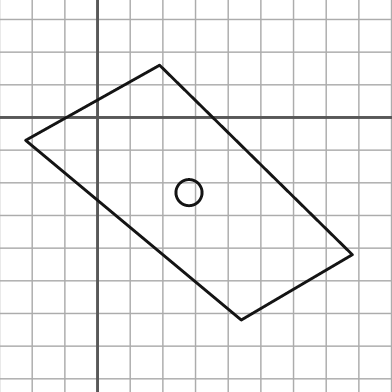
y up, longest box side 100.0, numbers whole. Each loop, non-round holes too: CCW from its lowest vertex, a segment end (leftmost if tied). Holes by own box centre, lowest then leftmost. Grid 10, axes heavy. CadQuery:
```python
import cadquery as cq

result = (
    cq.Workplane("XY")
    .moveTo(44.0, -62.0)
    .lineTo(78.0, -42.0)
    .lineTo(19.0, 16.0)
    .lineTo(-22.0, -7.0)
    .close()
    .moveTo(28.0, -23.0)
    .circle(4.0)
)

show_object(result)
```